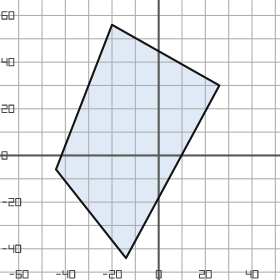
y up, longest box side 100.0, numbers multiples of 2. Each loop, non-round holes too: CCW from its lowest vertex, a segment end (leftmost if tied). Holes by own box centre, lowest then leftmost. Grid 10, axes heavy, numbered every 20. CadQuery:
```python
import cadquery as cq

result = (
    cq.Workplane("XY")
    .moveTo(-14.0, -44.0)
    .lineTo(26.0, 30.0)
    .lineTo(-20.0, 56.0)
    .lineTo(-44.0, -6.0)
    .close()
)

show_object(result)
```